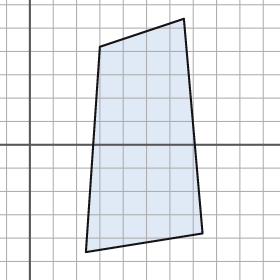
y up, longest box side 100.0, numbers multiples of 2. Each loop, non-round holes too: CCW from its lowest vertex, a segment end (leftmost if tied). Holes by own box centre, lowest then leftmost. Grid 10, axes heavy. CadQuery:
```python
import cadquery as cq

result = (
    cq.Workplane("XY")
    .moveTo(24.0, -46.0)
    .lineTo(74.0, -38.0)
    .lineTo(66.0, 54.0)
    .lineTo(30.0, 42.0)
    .close()
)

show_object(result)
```